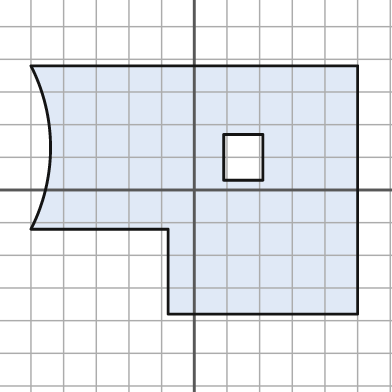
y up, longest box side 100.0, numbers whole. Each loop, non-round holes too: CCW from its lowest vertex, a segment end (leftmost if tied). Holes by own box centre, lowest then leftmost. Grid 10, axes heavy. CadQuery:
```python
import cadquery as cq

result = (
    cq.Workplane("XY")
    .moveTo(-8.0, -38.0)
    .lineTo(50.0, -38.0)
    .lineTo(50.0, 38.0)
    .lineTo(-50.0, 38.0)
    .threePointArc((-44.0, 13.0), (-50.0, -12.0))
    .lineTo(-8.0, -12.0)
    .close()
    .moveTo(9.0, 3.0)
    .lineTo(21.0, 3.0)
    .lineTo(21.0, 17.0)
    .lineTo(9.0, 17.0)
    .close()
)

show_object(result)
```